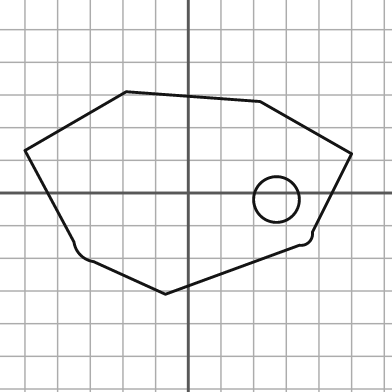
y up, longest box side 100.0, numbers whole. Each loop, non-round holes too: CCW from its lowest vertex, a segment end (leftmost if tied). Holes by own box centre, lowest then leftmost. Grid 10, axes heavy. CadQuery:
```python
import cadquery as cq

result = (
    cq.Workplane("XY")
    .moveTo(-7.0, -31.0)
    .lineTo(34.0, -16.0)
    .threePointArc((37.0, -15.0), (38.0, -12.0))
    .lineTo(50.0, 12.0)
    .lineTo(22.0, 28.0)
    .lineTo(-19.0, 31.0)
    .lineTo(-50.0, 13.0)
    .lineTo(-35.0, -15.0)
    .threePointArc((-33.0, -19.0), (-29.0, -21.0))
    .close()
    .moveTo(27.0, -2.0)
    .circle(7.0)
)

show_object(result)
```